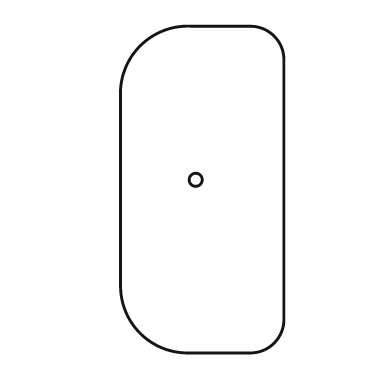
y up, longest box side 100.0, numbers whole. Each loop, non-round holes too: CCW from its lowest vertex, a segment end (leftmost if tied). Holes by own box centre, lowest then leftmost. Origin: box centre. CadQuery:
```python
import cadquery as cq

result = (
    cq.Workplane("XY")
    .moveTo(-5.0, -50.0)
    .lineTo(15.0, -50.0)
    .threePointArc((22.0, -47.0), (25.0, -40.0))
    .lineTo(25.0, 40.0)
    .threePointArc((22.0, 47.0), (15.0, 50.0))
    .lineTo(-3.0, 50.0)
    .threePointArc((-19.0, 44.0), (-25.0, 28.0))
    .lineTo(-25.0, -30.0)
    .threePointArc((-19.0, -44.0), (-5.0, -50.0))
    .close()
    .moveTo(-2.0, 3.0)
    .circle(2.0)
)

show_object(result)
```